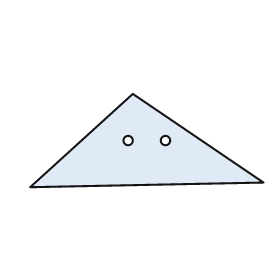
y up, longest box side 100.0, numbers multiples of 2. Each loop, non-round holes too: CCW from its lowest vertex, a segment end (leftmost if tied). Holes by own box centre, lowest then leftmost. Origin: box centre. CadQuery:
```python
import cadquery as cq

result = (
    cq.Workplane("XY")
    .moveTo(-50.0, -20.0)
    .lineTo(50.0, -18.0)
    .lineTo(-6.0, 20.0)
    .close()
    .moveTo(-8.0, 0.0)
    .circle(2.0)
    .moveTo(8.0, 0.0)
    .circle(2.0)
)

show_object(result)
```